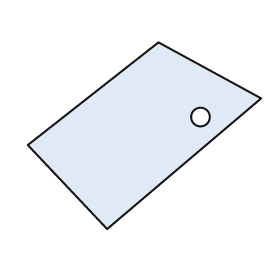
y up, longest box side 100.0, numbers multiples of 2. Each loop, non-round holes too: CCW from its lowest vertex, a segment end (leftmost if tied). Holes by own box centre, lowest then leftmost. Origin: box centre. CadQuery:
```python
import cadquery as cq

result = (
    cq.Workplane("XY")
    .moveTo(-16.0, -40.0)
    .lineTo(50.0, 16.0)
    .lineTo(6.0, 40.0)
    .lineTo(-50.0, -4.0)
    .close()
    .moveTo(24.0, 8.0)
    .circle(4.0)
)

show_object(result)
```